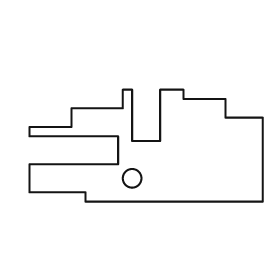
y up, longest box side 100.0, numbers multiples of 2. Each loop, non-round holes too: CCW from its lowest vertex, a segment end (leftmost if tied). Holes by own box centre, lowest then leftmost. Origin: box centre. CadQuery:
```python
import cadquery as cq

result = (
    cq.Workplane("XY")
    .moveTo(-26.0, -24.0)
    .lineTo(50.0, -24.0)
    .lineTo(50.0, 12.0)
    .lineTo(34.0, 12.0)
    .lineTo(34.0, 20.0)
    .lineTo(16.0, 20.0)
    .lineTo(16.0, 24.0)
    .lineTo(6.0, 24.0)
    .lineTo(6.0, 2.0)
    .lineTo(-6.0, 2.0)
    .lineTo(-6.0, 24.0)
    .lineTo(-10.0, 24.0)
    .lineTo(-10.0, 16.0)
    .lineTo(-32.0, 16.0)
    .lineTo(-32.0, 8.0)
    .lineTo(-50.0, 8.0)
    .lineTo(-50.0, 4.0)
    .lineTo(-12.0, 4.0)
    .lineTo(-12.0, -8.0)
    .lineTo(-50.0, -8.0)
    .lineTo(-50.0, -20.0)
    .lineTo(-26.0, -20.0)
    .close()
    .moveTo(-6.0, -14.0)
    .circle(4.0)
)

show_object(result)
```